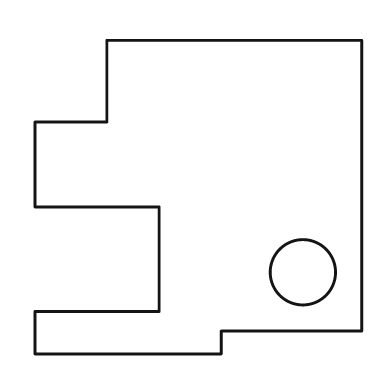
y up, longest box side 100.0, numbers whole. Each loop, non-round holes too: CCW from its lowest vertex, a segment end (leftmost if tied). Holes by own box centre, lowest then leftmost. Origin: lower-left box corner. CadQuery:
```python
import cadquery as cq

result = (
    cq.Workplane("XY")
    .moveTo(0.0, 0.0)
    .lineTo(57.0, 0.0)
    .lineTo(57.0, 7.0)
    .lineTo(100.0, 7.0)
    .lineTo(100.0, 96.0)
    .lineTo(22.0, 96.0)
    .lineTo(22.0, 71.0)
    .lineTo(0.0, 71.0)
    .lineTo(0.0, 45.0)
    .lineTo(38.0, 45.0)
    .lineTo(38.0, 13.0)
    .lineTo(0.0, 13.0)
    .close()
    .moveTo(82.0, 25.0)
    .circle(10.0)
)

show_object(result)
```